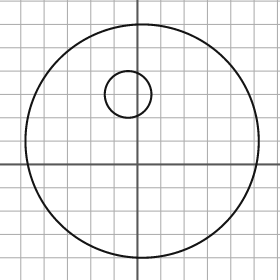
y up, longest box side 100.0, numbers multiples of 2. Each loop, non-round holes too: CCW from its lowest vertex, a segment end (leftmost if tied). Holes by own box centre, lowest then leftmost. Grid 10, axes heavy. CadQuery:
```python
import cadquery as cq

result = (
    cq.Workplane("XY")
    .moveTo(2.0, 10.0)
    .circle(50.0)
    .moveTo(-4.0, 30.0)
    .circle(10.0)
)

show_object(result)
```